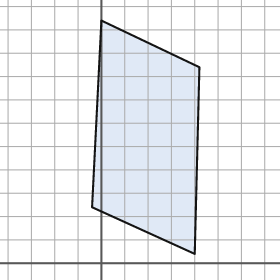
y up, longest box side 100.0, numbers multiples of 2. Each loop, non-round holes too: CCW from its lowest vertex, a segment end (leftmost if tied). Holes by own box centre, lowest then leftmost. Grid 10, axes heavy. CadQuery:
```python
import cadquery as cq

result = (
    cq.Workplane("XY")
    .moveTo(40.0, 4.0)
    .lineTo(42.0, 84.0)
    .lineTo(0.0, 104.0)
    .lineTo(-4.0, 24.0)
    .close()
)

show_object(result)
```